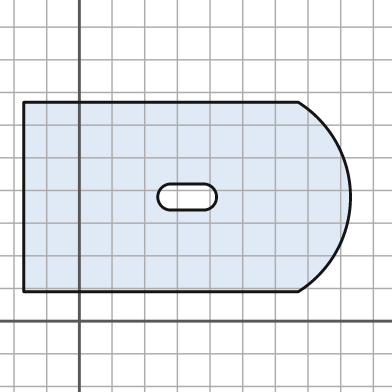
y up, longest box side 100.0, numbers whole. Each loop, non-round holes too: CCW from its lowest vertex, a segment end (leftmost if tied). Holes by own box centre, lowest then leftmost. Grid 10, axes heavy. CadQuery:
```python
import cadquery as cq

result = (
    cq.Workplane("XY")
    .moveTo(-17.0, 9.0)
    .lineTo(67.0, 9.0)
    .threePointArc((83.0, 38.0), (67.0, 67.0))
    .lineTo(-17.0, 67.0)
    .close()
    .moveTo(28.0, 34.0)
    .lineTo(38.0, 34.0)
    .threePointArc((42.0, 38.0), (38.0, 42.0))
    .lineTo(28.0, 42.0)
    .threePointArc((24.0, 38.0), (28.0, 34.0))
    .close()
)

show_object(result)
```